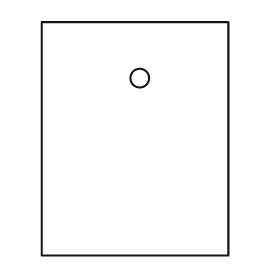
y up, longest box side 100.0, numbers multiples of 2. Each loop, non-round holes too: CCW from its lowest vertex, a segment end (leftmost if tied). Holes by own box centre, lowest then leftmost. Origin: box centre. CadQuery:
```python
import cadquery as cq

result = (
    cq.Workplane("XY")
    .moveTo(-40.0, -50.0)
    .lineTo(40.0, -50.0)
    .lineTo(40.0, 50.0)
    .lineTo(-40.0, 50.0)
    .close()
    .moveTo(2.0, 26.0)
    .circle(4.0)
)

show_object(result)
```